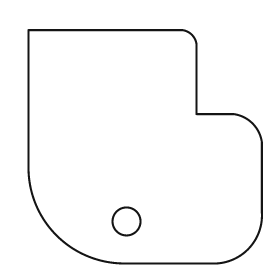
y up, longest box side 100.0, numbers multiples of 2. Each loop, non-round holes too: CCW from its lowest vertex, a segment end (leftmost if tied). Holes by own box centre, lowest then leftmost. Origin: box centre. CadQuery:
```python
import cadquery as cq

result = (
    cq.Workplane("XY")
    .moveTo(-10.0, -50.0)
    .lineTo(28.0, -50.0)
    .threePointArc((44.0, -44.0), (50.0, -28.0))
    .lineTo(50.0, 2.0)
    .threePointArc((46.0, 10.0), (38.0, 14.0))
    .lineTo(22.0, 14.0)
    .lineTo(22.0, 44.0)
    .threePointArc((20.0, 48.0), (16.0, 50.0))
    .lineTo(-50.0, 50.0)
    .lineTo(-50.0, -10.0)
    .threePointArc((-38.0, -38.0), (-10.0, -50.0))
    .close()
    .moveTo(-8.0, -32.0)
    .circle(6.0)
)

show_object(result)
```